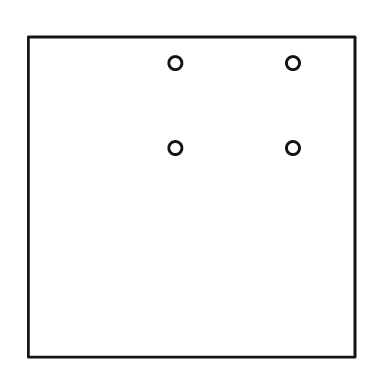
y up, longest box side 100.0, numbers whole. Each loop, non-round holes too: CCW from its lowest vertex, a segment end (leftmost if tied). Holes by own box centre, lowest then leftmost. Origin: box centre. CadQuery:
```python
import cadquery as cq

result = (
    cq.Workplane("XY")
    .moveTo(-50.0, -49.0)
    .lineTo(50.0, -49.0)
    .lineTo(50.0, 49.0)
    .lineTo(-50.0, 49.0)
    .close()
    .moveTo(-5.0, 15.0)
    .circle(2.0)
    .moveTo(31.0, 15.0)
    .circle(2.0)
    .moveTo(-5.0, 41.0)
    .circle(2.0)
    .moveTo(31.0, 41.0)
    .circle(2.0)
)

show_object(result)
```